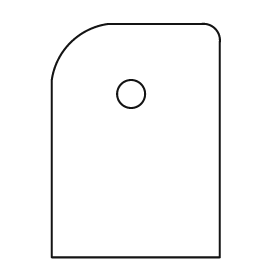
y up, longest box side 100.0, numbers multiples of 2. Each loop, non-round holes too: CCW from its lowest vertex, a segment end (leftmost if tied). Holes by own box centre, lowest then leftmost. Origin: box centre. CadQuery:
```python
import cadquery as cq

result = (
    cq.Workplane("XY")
    .moveTo(-36.0, -50.0)
    .lineTo(36.0, -50.0)
    .lineTo(36.0, 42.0)
    .threePointArc((34.0, 48.0), (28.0, 50.0))
    .lineTo(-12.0, 50.0)
    .threePointArc((-28.0, 42.0), (-36.0, 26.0))
    .close()
    .moveTo(-2.0, 20.0)
    .circle(6.0)
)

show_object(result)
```